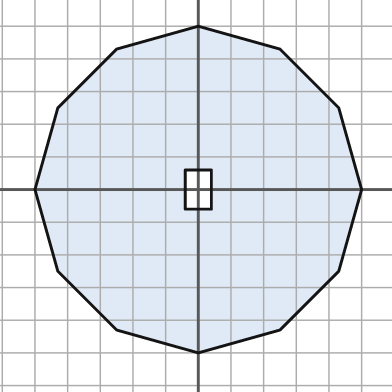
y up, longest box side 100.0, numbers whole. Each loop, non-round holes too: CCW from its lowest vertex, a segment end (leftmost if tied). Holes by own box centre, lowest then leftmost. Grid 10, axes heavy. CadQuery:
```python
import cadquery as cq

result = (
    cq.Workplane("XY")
    .moveTo(0.0, -50.0)
    .lineTo(25.0, -43.0)
    .lineTo(43.0, -25.0)
    .lineTo(50.0, 0.0)
    .lineTo(43.0, 25.0)
    .lineTo(25.0, 43.0)
    .lineTo(0.0, 50.0)
    .lineTo(-25.0, 43.0)
    .lineTo(-43.0, 25.0)
    .lineTo(-50.0, 0.0)
    .lineTo(-43.0, -25.0)
    .lineTo(-25.0, -43.0)
    .close()
    .moveTo(-4.0, -6.0)
    .lineTo(4.0, -6.0)
    .lineTo(4.0, 6.0)
    .lineTo(-4.0, 6.0)
    .close()
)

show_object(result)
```